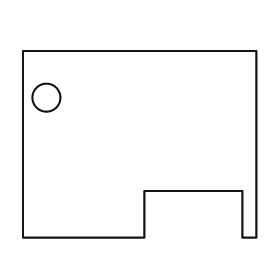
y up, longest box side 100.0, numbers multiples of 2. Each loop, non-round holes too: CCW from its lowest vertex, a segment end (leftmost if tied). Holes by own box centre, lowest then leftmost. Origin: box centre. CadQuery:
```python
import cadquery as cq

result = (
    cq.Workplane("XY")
    .moveTo(-50.0, -40.0)
    .lineTo(2.0, -40.0)
    .lineTo(2.0, -20.0)
    .lineTo(44.0, -20.0)
    .lineTo(44.0, -40.0)
    .lineTo(50.0, -40.0)
    .lineTo(50.0, 40.0)
    .lineTo(-50.0, 40.0)
    .close()
    .moveTo(-40.0, 20.0)
    .circle(6.0)
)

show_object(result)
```